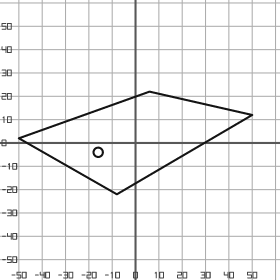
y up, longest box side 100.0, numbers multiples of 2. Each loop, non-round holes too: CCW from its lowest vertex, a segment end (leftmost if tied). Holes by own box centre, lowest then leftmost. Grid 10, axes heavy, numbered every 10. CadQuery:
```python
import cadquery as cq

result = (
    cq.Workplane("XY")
    .moveTo(-8.0, -22.0)
    .lineTo(50.0, 12.0)
    .lineTo(6.0, 22.0)
    .lineTo(-50.0, 2.0)
    .close()
    .moveTo(-16.0, -4.0)
    .circle(2.0)
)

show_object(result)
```